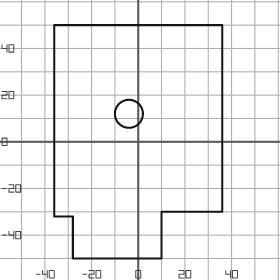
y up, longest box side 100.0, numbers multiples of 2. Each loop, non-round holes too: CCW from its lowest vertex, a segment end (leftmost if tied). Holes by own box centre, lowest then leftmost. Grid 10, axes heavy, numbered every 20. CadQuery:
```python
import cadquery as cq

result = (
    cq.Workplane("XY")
    .moveTo(-28.0, -50.0)
    .lineTo(10.0, -50.0)
    .lineTo(10.0, -30.0)
    .lineTo(36.0, -30.0)
    .lineTo(36.0, 50.0)
    .lineTo(-36.0, 50.0)
    .lineTo(-36.0, -32.0)
    .lineTo(-28.0, -32.0)
    .close()
    .moveTo(-4.0, 12.0)
    .circle(6.0)
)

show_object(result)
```